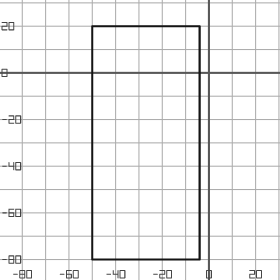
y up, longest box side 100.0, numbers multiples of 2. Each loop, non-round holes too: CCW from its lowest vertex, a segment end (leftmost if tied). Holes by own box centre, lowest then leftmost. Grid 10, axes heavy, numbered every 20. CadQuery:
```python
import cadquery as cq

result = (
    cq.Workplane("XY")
    .moveTo(-50.0, -80.0)
    .lineTo(-4.0, -80.0)
    .lineTo(-4.0, 20.0)
    .lineTo(-50.0, 20.0)
    .close()
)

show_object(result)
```